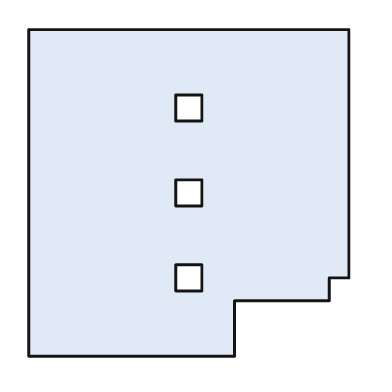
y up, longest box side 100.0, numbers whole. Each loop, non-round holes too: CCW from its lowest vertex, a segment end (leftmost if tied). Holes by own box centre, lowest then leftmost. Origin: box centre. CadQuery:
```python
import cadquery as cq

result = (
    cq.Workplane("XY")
    .moveTo(-49.0, -50.0)
    .lineTo(14.0, -50.0)
    .lineTo(14.0, -33.0)
    .lineTo(43.0, -33.0)
    .lineTo(43.0, -26.0)
    .lineTo(49.0, -26.0)
    .lineTo(49.0, 50.0)
    .lineTo(-49.0, 50.0)
    .close()
    .moveTo(-4.0, -30.0)
    .lineTo(4.0, -30.0)
    .lineTo(4.0, -22.0)
    .lineTo(-4.0, -22.0)
    .close()
    .moveTo(-4.0, -4.0)
    .lineTo(4.0, -4.0)
    .lineTo(4.0, 4.0)
    .lineTo(-4.0, 4.0)
    .close()
    .moveTo(-4.0, 22.0)
    .lineTo(4.0, 22.0)
    .lineTo(4.0, 30.0)
    .lineTo(-4.0, 30.0)
    .close()
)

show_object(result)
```